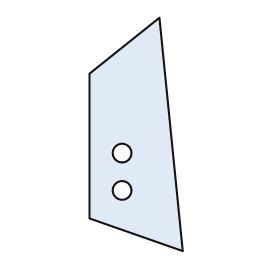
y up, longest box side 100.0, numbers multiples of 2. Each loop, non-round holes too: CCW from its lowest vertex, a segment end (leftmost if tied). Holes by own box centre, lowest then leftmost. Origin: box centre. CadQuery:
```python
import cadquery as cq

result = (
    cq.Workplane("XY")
    .moveTo(20.0, -50.0)
    .lineTo(10.0, 50.0)
    .lineTo(-20.0, 26.0)
    .lineTo(-20.0, -36.0)
    .close()
    .moveTo(-6.0, -24.0)
    .circle(4.0)
    .moveTo(-6.0, -8.0)
    .circle(4.0)
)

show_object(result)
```